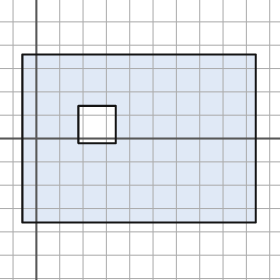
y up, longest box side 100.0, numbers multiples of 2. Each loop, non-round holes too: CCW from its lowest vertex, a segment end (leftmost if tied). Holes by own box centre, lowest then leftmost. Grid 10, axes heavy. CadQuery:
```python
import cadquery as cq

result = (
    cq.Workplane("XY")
    .moveTo(-6.0, -36.0)
    .lineTo(94.0, -36.0)
    .lineTo(94.0, 36.0)
    .lineTo(-6.0, 36.0)
    .close()
    .moveTo(18.0, -2.0)
    .lineTo(34.0, -2.0)
    .lineTo(34.0, 14.0)
    .lineTo(18.0, 14.0)
    .close()
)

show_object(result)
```